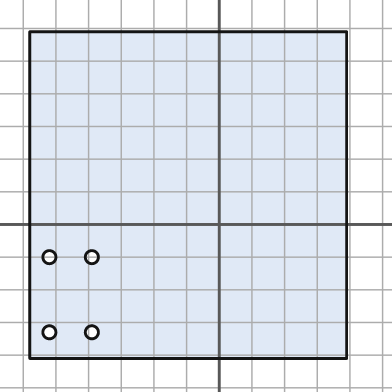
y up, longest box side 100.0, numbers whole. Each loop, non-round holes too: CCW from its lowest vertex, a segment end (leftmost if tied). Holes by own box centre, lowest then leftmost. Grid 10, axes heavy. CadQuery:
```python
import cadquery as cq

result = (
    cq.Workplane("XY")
    .moveTo(-58.0, -41.0)
    .lineTo(39.0, -41.0)
    .lineTo(39.0, 59.0)
    .lineTo(-58.0, 59.0)
    .close()
    .moveTo(-52.0, -33.0)
    .circle(2.0)
    .moveTo(-39.0, -33.0)
    .circle(2.0)
    .moveTo(-52.0, -10.0)
    .circle(2.0)
    .moveTo(-39.0, -10.0)
    .circle(2.0)
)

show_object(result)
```